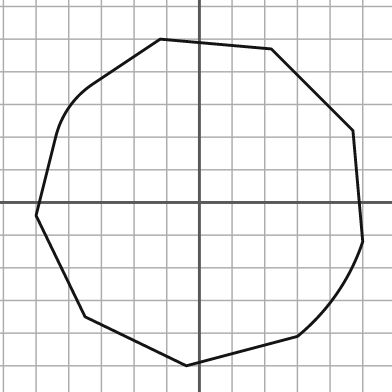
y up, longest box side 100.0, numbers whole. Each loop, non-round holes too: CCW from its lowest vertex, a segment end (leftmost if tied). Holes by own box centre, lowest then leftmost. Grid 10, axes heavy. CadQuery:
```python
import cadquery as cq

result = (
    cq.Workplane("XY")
    .moveTo(-4.0, -50.0)
    .lineTo(30.0, -41.0)
    .threePointArc((42.0, -28.0), (50.0, -12.0))
    .lineTo(47.0, 22.0)
    .lineTo(22.0, 47.0)
    .lineTo(-12.0, 50.0)
    .lineTo(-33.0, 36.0)
    .threePointArc((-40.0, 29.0), (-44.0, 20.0))
    .lineTo(-50.0, -4.0)
    .lineTo(-35.0, -35.0)
    .close()
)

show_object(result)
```